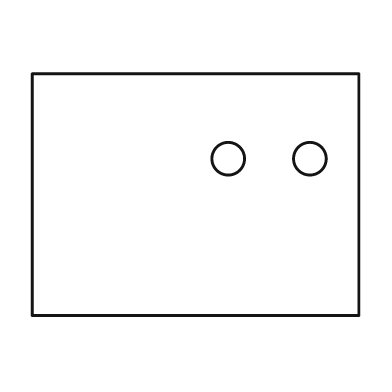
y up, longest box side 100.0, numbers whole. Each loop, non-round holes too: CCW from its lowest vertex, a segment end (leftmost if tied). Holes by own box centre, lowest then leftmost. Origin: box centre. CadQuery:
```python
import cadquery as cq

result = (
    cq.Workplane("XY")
    .moveTo(-50.0, -37.0)
    .lineTo(50.0, -37.0)
    .lineTo(50.0, 37.0)
    .lineTo(-50.0, 37.0)
    .close()
    .moveTo(10.0, 11.0)
    .circle(5.0)
    .moveTo(35.0, 11.0)
    .circle(5.0)
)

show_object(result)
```